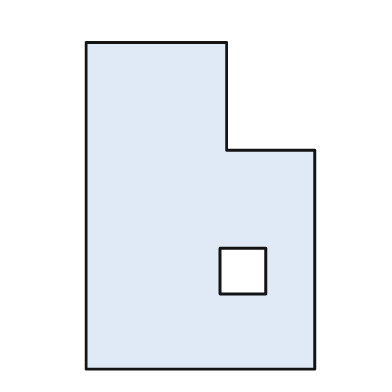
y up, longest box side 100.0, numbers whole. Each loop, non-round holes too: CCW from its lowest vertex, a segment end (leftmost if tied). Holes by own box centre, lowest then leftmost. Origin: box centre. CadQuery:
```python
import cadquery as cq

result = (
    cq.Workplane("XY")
    .moveTo(-35.0, -50.0)
    .lineTo(35.0, -50.0)
    .lineTo(35.0, 17.0)
    .lineTo(8.0, 17.0)
    .lineTo(8.0, 50.0)
    .lineTo(-35.0, 50.0)
    .close()
    .moveTo(6.0, -27.0)
    .lineTo(20.0, -27.0)
    .lineTo(20.0, -13.0)
    .lineTo(6.0, -13.0)
    .close()
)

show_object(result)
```